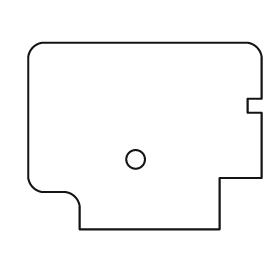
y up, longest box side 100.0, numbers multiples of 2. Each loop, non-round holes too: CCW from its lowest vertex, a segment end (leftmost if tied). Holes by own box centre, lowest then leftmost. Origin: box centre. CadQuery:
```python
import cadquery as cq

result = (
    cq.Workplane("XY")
    .moveTo(-28.0, -40.0)
    .lineTo(32.0, -40.0)
    .lineTo(32.0, -18.0)
    .lineTo(50.0, -18.0)
    .lineTo(50.0, 10.0)
    .lineTo(44.0, 10.0)
    .lineTo(44.0, 16.0)
    .lineTo(50.0, 16.0)
    .lineTo(50.0, 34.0)
    .threePointArc((48.0, 38.0), (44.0, 40.0))
    .lineTo(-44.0, 40.0)
    .threePointArc((-48.0, 38.0), (-50.0, 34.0))
    .lineTo(-50.0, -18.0)
    .threePointArc((-48.0, -22.0), (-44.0, -24.0))
    .lineTo(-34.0, -24.0)
    .threePointArc((-30.0, -26.0), (-28.0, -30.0))
    .close()
    .moveTo(-4.0, -10.0)
    .circle(4.0)
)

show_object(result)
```